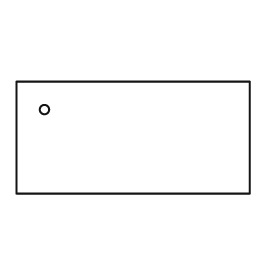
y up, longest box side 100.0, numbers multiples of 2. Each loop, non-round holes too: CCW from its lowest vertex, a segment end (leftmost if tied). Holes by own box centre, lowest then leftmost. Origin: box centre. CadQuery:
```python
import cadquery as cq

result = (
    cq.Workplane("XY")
    .moveTo(-50.0, -24.0)
    .lineTo(50.0, -24.0)
    .lineTo(50.0, 24.0)
    .lineTo(-50.0, 24.0)
    .close()
    .moveTo(-38.0, 12.0)
    .circle(2.0)
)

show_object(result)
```